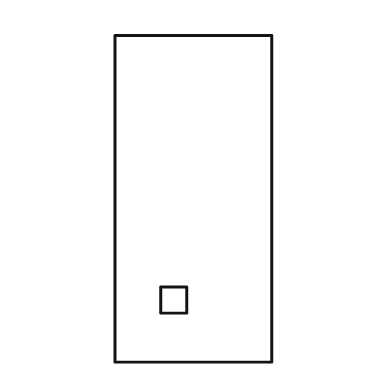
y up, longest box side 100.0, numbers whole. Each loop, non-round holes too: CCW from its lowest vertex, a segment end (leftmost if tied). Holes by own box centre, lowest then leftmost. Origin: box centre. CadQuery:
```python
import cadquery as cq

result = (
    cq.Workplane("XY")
    .moveTo(-24.0, -50.0)
    .lineTo(24.0, -50.0)
    .lineTo(24.0, 50.0)
    .lineTo(-24.0, 50.0)
    .close()
    .moveTo(-10.0, -35.0)
    .lineTo(-2.0, -35.0)
    .lineTo(-2.0, -27.0)
    .lineTo(-10.0, -27.0)
    .close()
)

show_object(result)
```